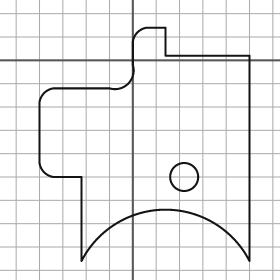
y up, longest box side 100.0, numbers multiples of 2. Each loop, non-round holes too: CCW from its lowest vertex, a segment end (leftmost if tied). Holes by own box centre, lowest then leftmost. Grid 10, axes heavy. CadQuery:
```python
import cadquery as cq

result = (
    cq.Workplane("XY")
    .moveTo(-22.0, -86.0)
    .threePointArc((14.0, -64.0), (50.0, -86.0))
    .lineTo(50.0, 2.0)
    .lineTo(14.0, 2.0)
    .lineTo(14.0, 14.0)
    .lineTo(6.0, 14.0)
    .threePointArc((2.0, 12.0), (0.0, 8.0))
    .lineTo(0.0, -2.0)
    .threePointArc((-2.0, -10.0), (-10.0, -12.0))
    .lineTo(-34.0, -12.0)
    .threePointArc((-38.0, -14.0), (-40.0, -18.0))
    .lineTo(-40.0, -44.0)
    .threePointArc((-38.0, -48.0), (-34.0, -50.0))
    .lineTo(-22.0, -50.0)
    .close()
    .moveTo(22.0, -50.0)
    .circle(6.0)
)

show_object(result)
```